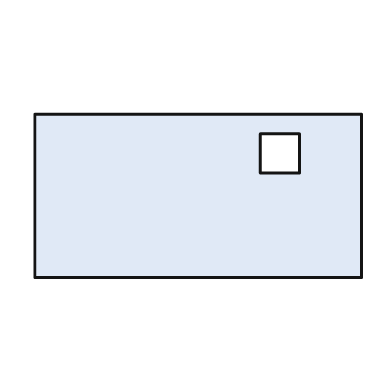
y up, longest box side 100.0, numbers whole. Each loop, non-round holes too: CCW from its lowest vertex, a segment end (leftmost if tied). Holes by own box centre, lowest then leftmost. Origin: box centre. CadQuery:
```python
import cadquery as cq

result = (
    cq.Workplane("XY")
    .moveTo(-50.0, -25.0)
    .lineTo(50.0, -25.0)
    .lineTo(50.0, 25.0)
    .lineTo(-50.0, 25.0)
    .close()
    .moveTo(19.0, 7.0)
    .lineTo(31.0, 7.0)
    .lineTo(31.0, 19.0)
    .lineTo(19.0, 19.0)
    .close()
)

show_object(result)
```